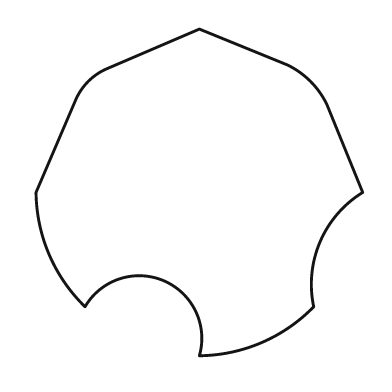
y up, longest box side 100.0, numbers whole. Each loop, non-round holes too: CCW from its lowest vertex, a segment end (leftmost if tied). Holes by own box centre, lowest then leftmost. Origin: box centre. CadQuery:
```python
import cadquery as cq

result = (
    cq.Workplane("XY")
    .moveTo(0.0, -50.0)
    .threePointArc((19.0, -46.0), (35.0, -35.0))
    .threePointArc((37.0, -15.0), (50.0, 0.0))
    .lineTo(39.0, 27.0)
    .threePointArc((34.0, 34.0), (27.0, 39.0))
    .lineTo(0.0, 50.0)
    .lineTo(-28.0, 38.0)
    .threePointArc((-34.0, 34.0), (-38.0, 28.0))
    .lineTo(-50.0, 0.0)
    .threePointArc((-46.0, -19.0), (-35.0, -35.0))
    .threePointArc((-11.0, -27.0), (0.0, -50.0))
    .close()
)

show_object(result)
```